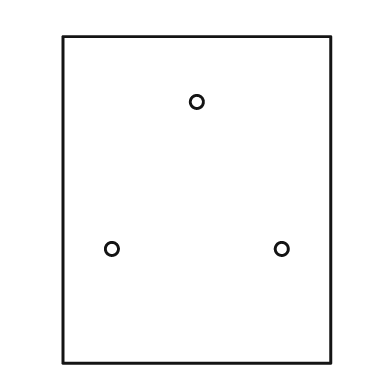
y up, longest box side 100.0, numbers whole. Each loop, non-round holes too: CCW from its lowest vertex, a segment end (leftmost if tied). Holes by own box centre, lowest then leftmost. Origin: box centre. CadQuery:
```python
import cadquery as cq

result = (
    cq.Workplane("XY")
    .moveTo(-41.0, -50.0)
    .lineTo(41.0, -50.0)
    .lineTo(41.0, 50.0)
    .lineTo(-41.0, 50.0)
    .close()
    .moveTo(-26.0, -15.0)
    .circle(2.0)
    .moveTo(26.0, -15.0)
    .circle(2.0)
    .moveTo(0.0, 30.0)
    .circle(2.0)
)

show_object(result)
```